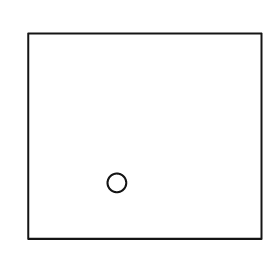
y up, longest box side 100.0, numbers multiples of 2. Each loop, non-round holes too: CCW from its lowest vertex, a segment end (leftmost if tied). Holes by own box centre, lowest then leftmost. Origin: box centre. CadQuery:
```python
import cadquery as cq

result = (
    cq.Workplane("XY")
    .moveTo(-50.0, -44.0)
    .lineTo(50.0, -44.0)
    .lineTo(50.0, 44.0)
    .lineTo(-50.0, 44.0)
    .close()
    .moveTo(-12.0, -20.0)
    .circle(4.0)
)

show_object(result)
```